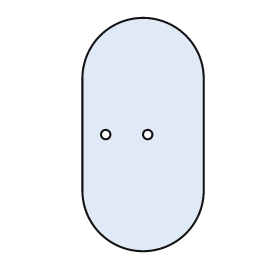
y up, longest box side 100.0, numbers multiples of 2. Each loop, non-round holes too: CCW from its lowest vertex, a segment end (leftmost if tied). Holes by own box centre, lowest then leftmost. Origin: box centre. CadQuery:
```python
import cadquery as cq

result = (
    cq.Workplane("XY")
    .moveTo(-26.0, -24.0)
    .threePointArc((0.0, -50.0), (26.0, -24.0))
    .lineTo(26.0, 24.0)
    .threePointArc((0.0, 50.0), (-26.0, 24.0))
    .close()
    .moveTo(-16.0, 0.0)
    .circle(2.0)
    .moveTo(2.0, 0.0)
    .circle(2.0)
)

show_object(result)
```